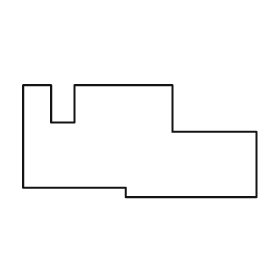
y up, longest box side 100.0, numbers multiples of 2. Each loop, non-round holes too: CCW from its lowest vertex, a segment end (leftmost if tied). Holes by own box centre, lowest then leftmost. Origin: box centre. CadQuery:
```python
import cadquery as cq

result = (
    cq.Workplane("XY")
    .moveTo(-6.0, -24.0)
    .lineTo(50.0, -24.0)
    .lineTo(50.0, 4.0)
    .lineTo(14.0, 4.0)
    .lineTo(14.0, 24.0)
    .lineTo(-28.0, 24.0)
    .lineTo(-28.0, 8.0)
    .lineTo(-38.0, 8.0)
    .lineTo(-38.0, 24.0)
    .lineTo(-50.0, 24.0)
    .lineTo(-50.0, -20.0)
    .lineTo(-6.0, -20.0)
    .close()
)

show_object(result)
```